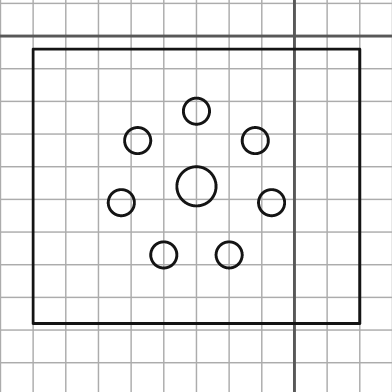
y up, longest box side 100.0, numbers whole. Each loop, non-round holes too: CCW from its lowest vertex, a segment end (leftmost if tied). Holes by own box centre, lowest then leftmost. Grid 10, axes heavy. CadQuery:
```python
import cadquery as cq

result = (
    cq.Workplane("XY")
    .moveTo(-80.0, -88.0)
    .lineTo(20.0, -88.0)
    .lineTo(20.0, -4.0)
    .lineTo(-80.0, -4.0)
    .close()
    .moveTo(-40.0, -67.0)
    .circle(4.0)
    .moveTo(-20.0, -67.0)
    .circle(4.0)
    .moveTo(-53.0, -51.0)
    .circle(4.0)
    .moveTo(-7.0, -51.0)
    .circle(4.0)
    .moveTo(-30.0, -46.0)
    .circle(6.0)
    .moveTo(-48.0, -32.0)
    .circle(4.0)
    .moveTo(-12.0, -32.0)
    .circle(4.0)
    .moveTo(-30.0, -23.0)
    .circle(4.0)
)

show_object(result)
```